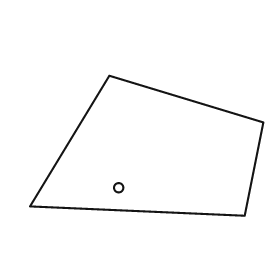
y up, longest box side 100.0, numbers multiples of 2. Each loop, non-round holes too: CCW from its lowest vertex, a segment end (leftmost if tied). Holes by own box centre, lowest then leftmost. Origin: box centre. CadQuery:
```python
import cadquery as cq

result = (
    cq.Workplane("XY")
    .moveTo(42.0, -30.0)
    .lineTo(50.0, 10.0)
    .lineTo(-16.0, 30.0)
    .lineTo(-50.0, -26.0)
    .close()
    .moveTo(-12.0, -18.0)
    .circle(2.0)
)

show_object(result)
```